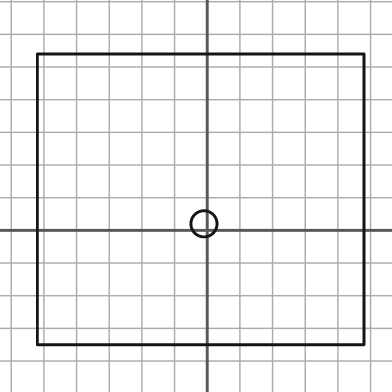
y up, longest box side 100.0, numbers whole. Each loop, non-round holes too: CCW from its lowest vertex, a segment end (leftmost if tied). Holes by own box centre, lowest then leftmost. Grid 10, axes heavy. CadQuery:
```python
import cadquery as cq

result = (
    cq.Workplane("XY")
    .moveTo(-52.0, -35.0)
    .lineTo(48.0, -35.0)
    .lineTo(48.0, 54.0)
    .lineTo(-52.0, 54.0)
    .close()
    .moveTo(-1.0, 2.0)
    .circle(4.0)
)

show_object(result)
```